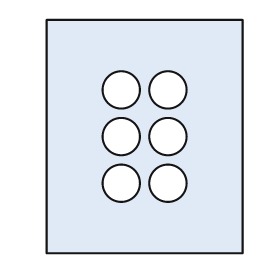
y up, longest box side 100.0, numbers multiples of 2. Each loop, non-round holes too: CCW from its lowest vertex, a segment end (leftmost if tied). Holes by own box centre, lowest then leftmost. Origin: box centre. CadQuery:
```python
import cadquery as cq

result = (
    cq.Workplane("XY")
    .moveTo(-42.0, -50.0)
    .lineTo(42.0, -50.0)
    .lineTo(42.0, 50.0)
    .lineTo(-42.0, 50.0)
    .close()
    .moveTo(-10.0, -20.0)
    .circle(8.0)
    .moveTo(10.0, -20.0)
    .circle(8.0)
    .moveTo(-10.0, 0.0)
    .circle(8.0)
    .moveTo(10.0, 0.0)
    .circle(8.0)
    .moveTo(-10.0, 20.0)
    .circle(8.0)
    .moveTo(10.0, 20.0)
    .circle(8.0)
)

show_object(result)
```